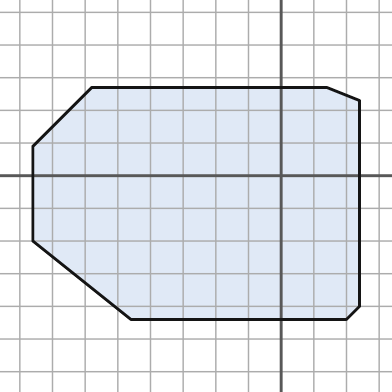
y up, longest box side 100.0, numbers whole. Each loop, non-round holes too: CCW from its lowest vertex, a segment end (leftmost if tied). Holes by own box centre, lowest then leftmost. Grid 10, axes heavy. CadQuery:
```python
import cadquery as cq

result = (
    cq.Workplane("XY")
    .moveTo(-46.0, -44.0)
    .lineTo(20.0, -44.0)
    .lineTo(24.0, -40.0)
    .lineTo(24.0, 23.0)
    .lineTo(14.0, 27.0)
    .lineTo(-58.0, 27.0)
    .lineTo(-76.0, 9.0)
    .lineTo(-76.0, -20.0)
    .close()
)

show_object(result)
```